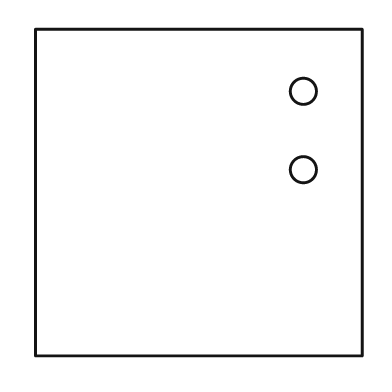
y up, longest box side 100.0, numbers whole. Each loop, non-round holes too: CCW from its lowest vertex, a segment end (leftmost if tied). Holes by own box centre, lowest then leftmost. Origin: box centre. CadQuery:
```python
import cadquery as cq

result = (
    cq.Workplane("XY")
    .moveTo(-50.0, -50.0)
    .lineTo(50.0, -50.0)
    .lineTo(50.0, 50.0)
    .lineTo(-50.0, 50.0)
    .close()
    .moveTo(32.0, 7.0)
    .circle(4.0)
    .moveTo(32.0, 31.0)
    .circle(4.0)
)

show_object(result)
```